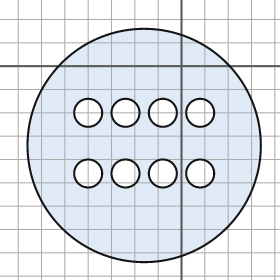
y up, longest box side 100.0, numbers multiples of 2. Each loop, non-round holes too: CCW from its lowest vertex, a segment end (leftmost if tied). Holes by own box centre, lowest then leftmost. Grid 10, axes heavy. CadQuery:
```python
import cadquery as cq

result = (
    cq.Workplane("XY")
    .moveTo(-16.0, -34.0)
    .circle(50.0)
    .moveTo(-40.0, -46.0)
    .circle(6.0)
    .moveTo(-24.0, -46.0)
    .circle(6.0)
    .moveTo(-8.0, -46.0)
    .circle(6.0)
    .moveTo(8.0, -46.0)
    .circle(6.0)
    .moveTo(-40.0, -20.0)
    .circle(6.0)
    .moveTo(-24.0, -20.0)
    .circle(6.0)
    .moveTo(-8.0, -20.0)
    .circle(6.0)
    .moveTo(8.0, -20.0)
    .circle(6.0)
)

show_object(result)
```